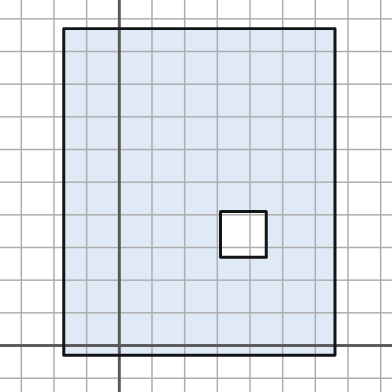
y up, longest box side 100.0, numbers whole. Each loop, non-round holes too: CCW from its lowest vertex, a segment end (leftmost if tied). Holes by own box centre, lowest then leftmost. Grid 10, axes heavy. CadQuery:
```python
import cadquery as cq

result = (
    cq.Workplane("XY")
    .moveTo(-17.0, -3.0)
    .lineTo(66.0, -3.0)
    .lineTo(66.0, 97.0)
    .lineTo(-17.0, 97.0)
    .close()
    .moveTo(31.0, 27.0)
    .lineTo(45.0, 27.0)
    .lineTo(45.0, 41.0)
    .lineTo(31.0, 41.0)
    .close()
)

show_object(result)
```